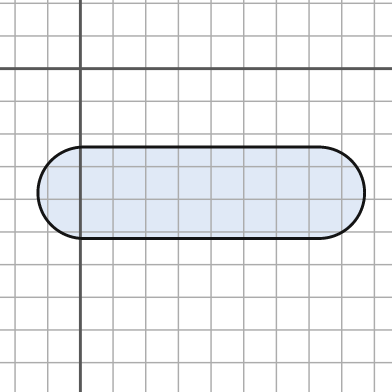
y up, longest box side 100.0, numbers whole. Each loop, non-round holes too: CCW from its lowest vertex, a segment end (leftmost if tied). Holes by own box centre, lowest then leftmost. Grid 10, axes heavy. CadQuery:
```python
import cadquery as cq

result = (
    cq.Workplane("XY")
    .moveTo(1.0, -52.0)
    .lineTo(73.0, -52.0)
    .threePointArc((87.0, -38.0), (73.0, -24.0))
    .lineTo(1.0, -24.0)
    .threePointArc((-13.0, -38.0), (1.0, -52.0))
    .close()
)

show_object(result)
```